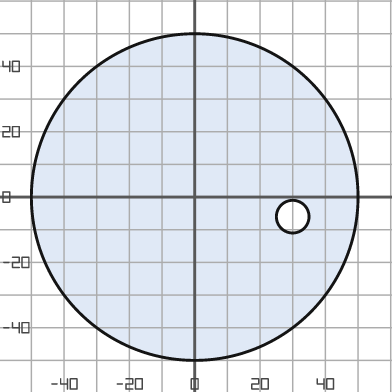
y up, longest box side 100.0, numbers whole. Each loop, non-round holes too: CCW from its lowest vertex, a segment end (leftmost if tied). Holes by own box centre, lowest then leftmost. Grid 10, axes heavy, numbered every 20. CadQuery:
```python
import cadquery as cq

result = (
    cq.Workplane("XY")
    .moveTo(0.0, 0.0)
    .circle(50.0)
    .moveTo(30.0, -6.0)
    .circle(5.0)
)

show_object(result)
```